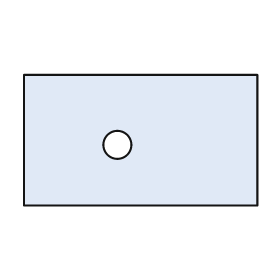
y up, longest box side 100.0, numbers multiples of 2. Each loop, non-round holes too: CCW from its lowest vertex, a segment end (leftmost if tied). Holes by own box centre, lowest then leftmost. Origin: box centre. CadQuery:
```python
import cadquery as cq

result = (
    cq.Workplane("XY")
    .moveTo(-50.0, -28.0)
    .lineTo(50.0, -28.0)
    .lineTo(50.0, 28.0)
    .lineTo(-50.0, 28.0)
    .close()
    .moveTo(-10.0, -2.0)
    .circle(6.0)
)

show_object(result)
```